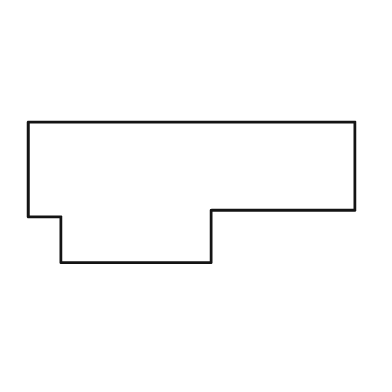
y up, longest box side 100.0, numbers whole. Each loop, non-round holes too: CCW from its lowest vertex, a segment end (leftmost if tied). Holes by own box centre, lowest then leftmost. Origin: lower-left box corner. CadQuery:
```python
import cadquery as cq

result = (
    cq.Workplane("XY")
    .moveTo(10.0, 0.0)
    .lineTo(56.0, 0.0)
    .lineTo(56.0, 16.0)
    .lineTo(100.0, 16.0)
    .lineTo(100.0, 43.0)
    .lineTo(0.0, 43.0)
    .lineTo(0.0, 14.0)
    .lineTo(10.0, 14.0)
    .close()
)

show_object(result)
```